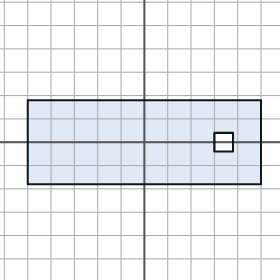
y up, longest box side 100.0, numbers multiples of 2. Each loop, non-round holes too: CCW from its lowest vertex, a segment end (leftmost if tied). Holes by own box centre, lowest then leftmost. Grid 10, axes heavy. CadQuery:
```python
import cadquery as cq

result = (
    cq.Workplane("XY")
    .moveTo(-50.0, -18.0)
    .lineTo(50.0, -18.0)
    .lineTo(50.0, 18.0)
    .lineTo(-50.0, 18.0)
    .close()
    .moveTo(30.0, -4.0)
    .lineTo(38.0, -4.0)
    .lineTo(38.0, 4.0)
    .lineTo(30.0, 4.0)
    .close()
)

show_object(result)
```